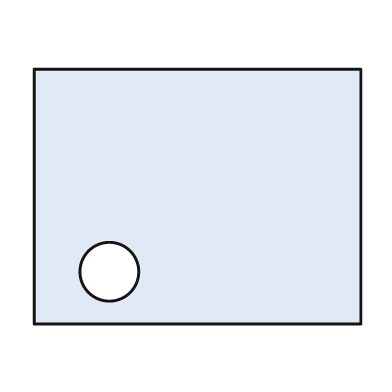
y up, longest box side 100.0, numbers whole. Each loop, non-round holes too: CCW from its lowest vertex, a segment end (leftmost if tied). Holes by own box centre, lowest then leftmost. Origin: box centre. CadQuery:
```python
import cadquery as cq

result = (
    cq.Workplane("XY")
    .moveTo(-50.0, -39.0)
    .lineTo(50.0, -39.0)
    .lineTo(50.0, 39.0)
    .lineTo(-50.0, 39.0)
    .close()
    .moveTo(-27.0, -23.0)
    .circle(9.0)
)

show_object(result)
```